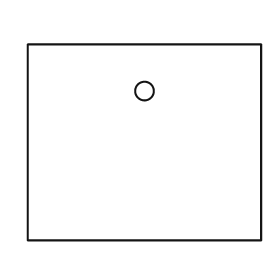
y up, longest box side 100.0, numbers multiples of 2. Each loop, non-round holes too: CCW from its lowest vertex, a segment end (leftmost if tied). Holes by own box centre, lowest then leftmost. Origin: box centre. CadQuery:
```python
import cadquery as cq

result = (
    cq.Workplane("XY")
    .moveTo(-50.0, -42.0)
    .lineTo(50.0, -42.0)
    .lineTo(50.0, 42.0)
    .lineTo(-50.0, 42.0)
    .close()
    .moveTo(0.0, 22.0)
    .circle(4.0)
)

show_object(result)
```